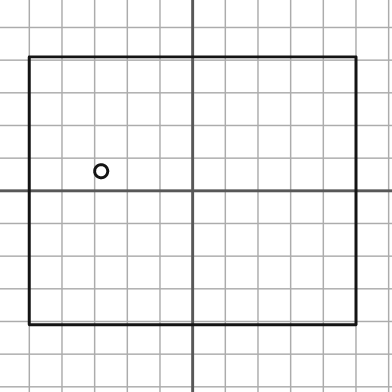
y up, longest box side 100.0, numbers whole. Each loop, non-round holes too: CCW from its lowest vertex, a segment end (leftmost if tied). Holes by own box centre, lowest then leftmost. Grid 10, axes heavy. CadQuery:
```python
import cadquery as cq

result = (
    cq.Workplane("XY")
    .moveTo(-50.0, -41.0)
    .lineTo(50.0, -41.0)
    .lineTo(50.0, 41.0)
    .lineTo(-50.0, 41.0)
    .close()
    .moveTo(-28.0, 6.0)
    .circle(2.0)
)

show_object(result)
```